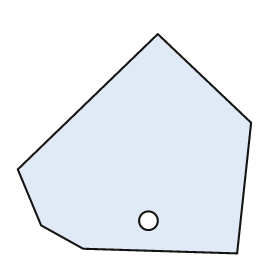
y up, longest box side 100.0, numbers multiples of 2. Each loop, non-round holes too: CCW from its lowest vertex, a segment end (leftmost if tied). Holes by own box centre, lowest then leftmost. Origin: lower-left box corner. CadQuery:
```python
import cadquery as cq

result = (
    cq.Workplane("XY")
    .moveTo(94.0, 0.0)
    .lineTo(100.0, 56.0)
    .lineTo(60.0, 94.0)
    .lineTo(0.0, 36.0)
    .lineTo(10.0, 12.0)
    .lineTo(28.0, 2.0)
    .close()
    .moveTo(56.0, 14.0)
    .circle(4.0)
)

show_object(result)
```